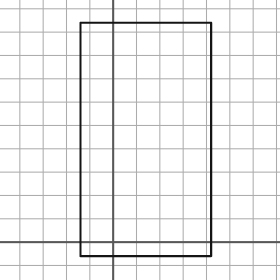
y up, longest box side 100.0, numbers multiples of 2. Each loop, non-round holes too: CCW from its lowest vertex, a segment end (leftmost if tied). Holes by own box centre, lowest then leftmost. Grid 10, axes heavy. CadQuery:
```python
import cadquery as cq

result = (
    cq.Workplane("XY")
    .moveTo(-14.0, -6.0)
    .lineTo(42.0, -6.0)
    .lineTo(42.0, 94.0)
    .lineTo(-14.0, 94.0)
    .close()
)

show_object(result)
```